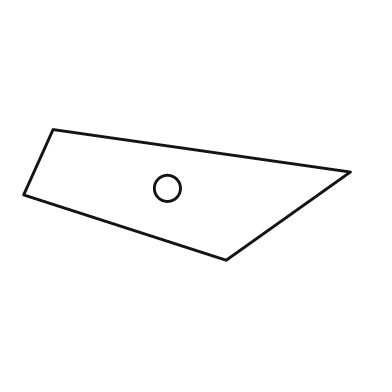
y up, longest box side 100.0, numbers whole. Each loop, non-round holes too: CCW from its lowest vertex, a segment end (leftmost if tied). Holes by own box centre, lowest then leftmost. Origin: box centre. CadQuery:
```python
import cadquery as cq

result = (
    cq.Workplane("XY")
    .moveTo(12.0, -20.0)
    .lineTo(50.0, 7.0)
    .lineTo(-41.0, 20.0)
    .lineTo(-50.0, 0.0)
    .close()
    .moveTo(-6.0, 2.0)
    .circle(4.0)
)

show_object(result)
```